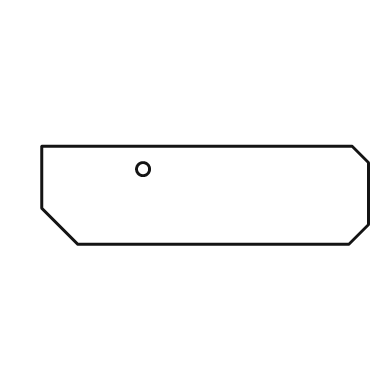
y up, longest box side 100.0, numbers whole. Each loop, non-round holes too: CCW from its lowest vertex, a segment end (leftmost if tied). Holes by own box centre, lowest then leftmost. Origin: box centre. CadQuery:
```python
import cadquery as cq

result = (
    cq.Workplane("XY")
    .moveTo(-39.0, -15.0)
    .lineTo(44.0, -15.0)
    .lineTo(50.0, -9.0)
    .lineTo(50.0, 10.0)
    .lineTo(45.0, 15.0)
    .lineTo(-50.0, 15.0)
    .lineTo(-50.0, -4.0)
    .close()
    .moveTo(-19.0, 8.0)
    .circle(2.0)
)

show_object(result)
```